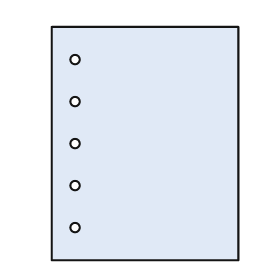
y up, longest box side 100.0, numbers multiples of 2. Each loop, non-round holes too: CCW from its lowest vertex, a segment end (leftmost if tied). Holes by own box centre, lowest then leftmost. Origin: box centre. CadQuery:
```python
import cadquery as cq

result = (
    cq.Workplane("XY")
    .moveTo(-40.0, -50.0)
    .lineTo(40.0, -50.0)
    .lineTo(40.0, 50.0)
    .lineTo(-40.0, 50.0)
    .close()
    .moveTo(-30.0, -36.0)
    .circle(2.0)
    .moveTo(-30.0, -18.0)
    .circle(2.0)
    .moveTo(-30.0, 0.0)
    .circle(2.0)
    .moveTo(-30.0, 18.0)
    .circle(2.0)
    .moveTo(-30.0, 36.0)
    .circle(2.0)
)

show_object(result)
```